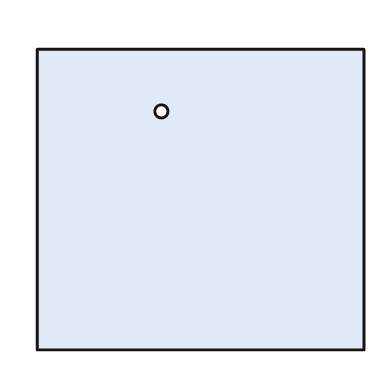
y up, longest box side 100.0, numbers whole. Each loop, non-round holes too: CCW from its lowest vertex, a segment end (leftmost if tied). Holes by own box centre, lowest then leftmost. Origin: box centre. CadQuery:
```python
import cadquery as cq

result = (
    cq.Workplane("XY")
    .moveTo(-50.0, -46.0)
    .lineTo(50.0, -46.0)
    .lineTo(50.0, 46.0)
    .lineTo(-50.0, 46.0)
    .close()
    .moveTo(-12.0, 27.0)
    .circle(2.0)
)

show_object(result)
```